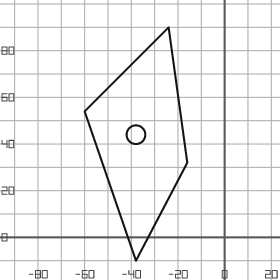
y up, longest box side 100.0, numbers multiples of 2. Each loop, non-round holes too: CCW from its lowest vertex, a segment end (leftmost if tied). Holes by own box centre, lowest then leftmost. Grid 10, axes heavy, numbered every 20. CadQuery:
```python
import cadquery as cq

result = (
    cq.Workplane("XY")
    .moveTo(-38.0, -10.0)
    .lineTo(-16.0, 32.0)
    .lineTo(-24.0, 90.0)
    .lineTo(-60.0, 54.0)
    .close()
    .moveTo(-38.0, 44.0)
    .circle(4.0)
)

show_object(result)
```